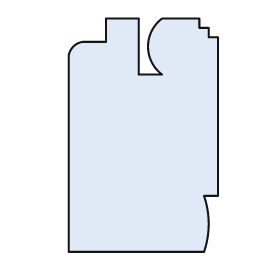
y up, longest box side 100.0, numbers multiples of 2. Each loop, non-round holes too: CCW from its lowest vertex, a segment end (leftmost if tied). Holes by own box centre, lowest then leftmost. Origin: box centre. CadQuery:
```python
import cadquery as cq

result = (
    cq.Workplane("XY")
    .moveTo(-32.0, -50.0)
    .lineTo(26.0, -50.0)
    .threePointArc((28.0, -38.0), (26.0, -26.0))
    .lineTo(32.0, -26.0)
    .lineTo(32.0, 42.0)
    .lineTo(28.0, 42.0)
    .lineTo(28.0, 46.0)
    .lineTo(24.0, 46.0)
    .lineTo(24.0, 50.0)
    .lineTo(8.0, 50.0)
    .threePointArc((2.0, 38.0), (8.0, 26.0))
    .lineTo(-2.0, 26.0)
    .lineTo(-2.0, 50.0)
    .lineTo(-16.0, 50.0)
    .lineTo(-16.0, 40.0)
    .lineTo(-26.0, 40.0)
    .threePointArc((-30.0, 38.0), (-32.0, 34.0))
    .close()
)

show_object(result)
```